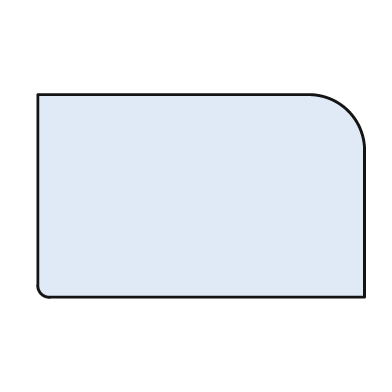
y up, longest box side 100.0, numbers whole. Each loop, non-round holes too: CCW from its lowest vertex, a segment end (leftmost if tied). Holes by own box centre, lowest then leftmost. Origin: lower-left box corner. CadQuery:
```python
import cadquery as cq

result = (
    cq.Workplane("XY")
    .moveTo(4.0, 0.0)
    .lineTo(100.0, 0.0)
    .lineTo(100.0, 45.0)
    .threePointArc((95.0, 57.0), (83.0, 62.0))
    .lineTo(0.0, 62.0)
    .lineTo(0.0, 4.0)
    .threePointArc((1.0, 1.0), (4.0, 0.0))
    .close()
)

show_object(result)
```